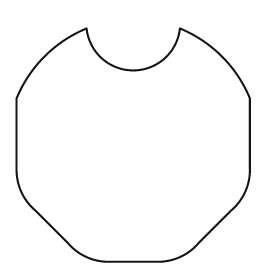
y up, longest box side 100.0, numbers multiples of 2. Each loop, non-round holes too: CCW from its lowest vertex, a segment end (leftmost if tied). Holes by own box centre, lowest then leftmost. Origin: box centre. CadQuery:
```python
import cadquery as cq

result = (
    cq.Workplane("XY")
    .moveTo(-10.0, -50.0)
    .lineTo(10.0, -50.0)
    .threePointArc((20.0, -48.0), (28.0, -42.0))
    .lineTo(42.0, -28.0)
    .threePointArc((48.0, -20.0), (50.0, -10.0))
    .lineTo(50.0, 20.0)
    .threePointArc((38.0, 38.0), (20.0, 50.0))
    .threePointArc((0.0, 32.0), (-20.0, 50.0))
    .threePointArc((-38.0, 38.0), (-50.0, 20.0))
    .lineTo(-50.0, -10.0)
    .threePointArc((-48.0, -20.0), (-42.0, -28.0))
    .lineTo(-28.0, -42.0)
    .threePointArc((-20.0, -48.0), (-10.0, -50.0))
    .close()
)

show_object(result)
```